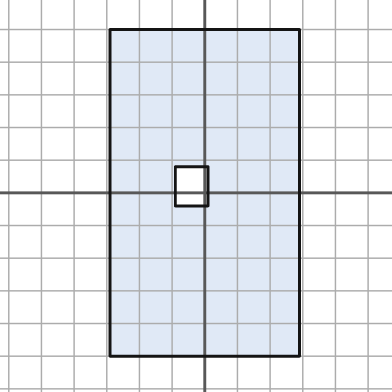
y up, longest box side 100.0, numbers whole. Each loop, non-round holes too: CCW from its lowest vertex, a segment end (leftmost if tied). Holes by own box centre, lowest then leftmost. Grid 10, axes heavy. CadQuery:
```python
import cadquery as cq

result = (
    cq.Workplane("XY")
    .moveTo(-29.0, -50.0)
    .lineTo(29.0, -50.0)
    .lineTo(29.0, 50.0)
    .lineTo(-29.0, 50.0)
    .close()
    .moveTo(-9.0, -4.0)
    .lineTo(1.0, -4.0)
    .lineTo(1.0, 8.0)
    .lineTo(-9.0, 8.0)
    .close()
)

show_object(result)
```